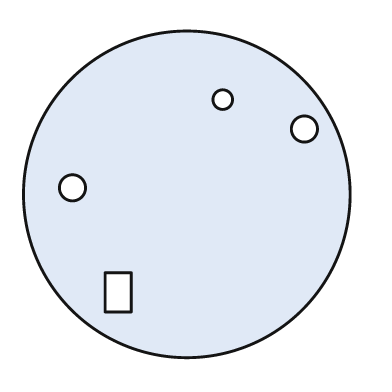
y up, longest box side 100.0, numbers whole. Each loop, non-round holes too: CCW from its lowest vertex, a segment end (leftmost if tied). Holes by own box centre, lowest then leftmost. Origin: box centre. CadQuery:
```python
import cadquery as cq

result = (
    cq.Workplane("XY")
    .moveTo(0.0, 0.0)
    .circle(50.0)
    .moveTo(-25.0, -36.0)
    .lineTo(-17.0, -36.0)
    .lineTo(-17.0, -24.0)
    .lineTo(-25.0, -24.0)
    .close()
    .moveTo(-35.0, 2.0)
    .circle(4.0)
    .moveTo(36.0, 20.0)
    .circle(4.0)
    .moveTo(11.0, 29.0)
    .circle(3.0)
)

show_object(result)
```